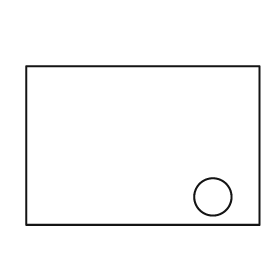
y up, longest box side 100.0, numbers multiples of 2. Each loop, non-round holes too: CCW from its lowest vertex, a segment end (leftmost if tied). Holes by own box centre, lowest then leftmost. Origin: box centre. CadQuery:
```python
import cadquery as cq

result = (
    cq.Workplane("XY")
    .moveTo(-50.0, -34.0)
    .lineTo(50.0, -34.0)
    .lineTo(50.0, 34.0)
    .lineTo(-50.0, 34.0)
    .close()
    .moveTo(30.0, -22.0)
    .circle(8.0)
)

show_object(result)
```